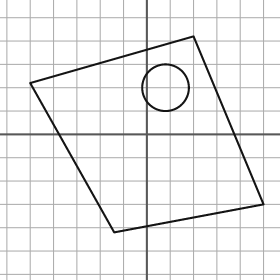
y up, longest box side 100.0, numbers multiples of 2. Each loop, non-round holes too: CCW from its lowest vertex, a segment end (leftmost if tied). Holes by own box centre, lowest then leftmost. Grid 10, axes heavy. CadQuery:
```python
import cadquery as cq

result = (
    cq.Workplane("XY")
    .moveTo(-14.0, -42.0)
    .lineTo(50.0, -30.0)
    .lineTo(20.0, 42.0)
    .lineTo(-50.0, 22.0)
    .close()
    .moveTo(8.0, 20.0)
    .circle(10.0)
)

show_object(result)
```